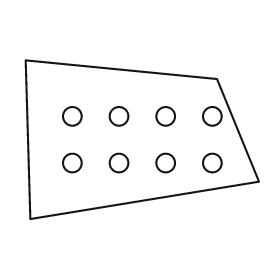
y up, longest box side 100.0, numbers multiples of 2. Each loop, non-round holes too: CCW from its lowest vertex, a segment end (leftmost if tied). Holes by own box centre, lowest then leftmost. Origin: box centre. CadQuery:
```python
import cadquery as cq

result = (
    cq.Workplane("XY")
    .moveTo(-48.0, -34.0)
    .lineTo(50.0, -18.0)
    .lineTo(32.0, 26.0)
    .lineTo(-50.0, 34.0)
    .close()
    .moveTo(-30.0, -10.0)
    .circle(4.0)
    .moveTo(-10.0, -10.0)
    .circle(4.0)
    .moveTo(10.0, -10.0)
    .circle(4.0)
    .moveTo(30.0, -10.0)
    .circle(4.0)
    .moveTo(-30.0, 10.0)
    .circle(4.0)
    .moveTo(-10.0, 10.0)
    .circle(4.0)
    .moveTo(10.0, 10.0)
    .circle(4.0)
    .moveTo(30.0, 10.0)
    .circle(4.0)
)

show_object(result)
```